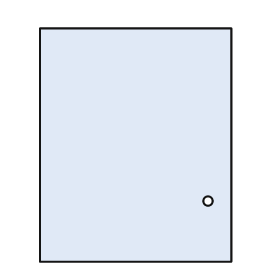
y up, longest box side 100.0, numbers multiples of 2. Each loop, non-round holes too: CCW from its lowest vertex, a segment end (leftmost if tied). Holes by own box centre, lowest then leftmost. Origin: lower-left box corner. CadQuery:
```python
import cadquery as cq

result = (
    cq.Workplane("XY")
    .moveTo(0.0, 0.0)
    .lineTo(82.0, 0.0)
    .lineTo(82.0, 100.0)
    .lineTo(0.0, 100.0)
    .close()
    .moveTo(72.0, 26.0)
    .circle(2.0)
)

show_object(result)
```